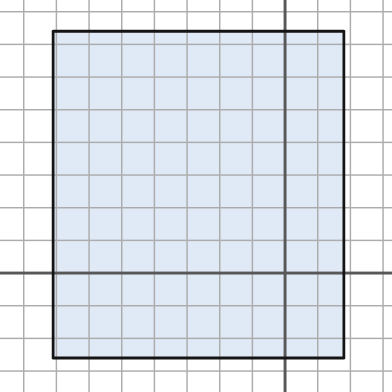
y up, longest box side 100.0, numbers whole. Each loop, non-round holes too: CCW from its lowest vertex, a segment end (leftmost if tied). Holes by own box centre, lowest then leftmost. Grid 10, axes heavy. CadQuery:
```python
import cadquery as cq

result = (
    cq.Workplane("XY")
    .moveTo(-71.0, -26.0)
    .lineTo(18.0, -26.0)
    .lineTo(18.0, 74.0)
    .lineTo(-71.0, 74.0)
    .close()
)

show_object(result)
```